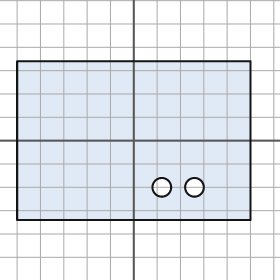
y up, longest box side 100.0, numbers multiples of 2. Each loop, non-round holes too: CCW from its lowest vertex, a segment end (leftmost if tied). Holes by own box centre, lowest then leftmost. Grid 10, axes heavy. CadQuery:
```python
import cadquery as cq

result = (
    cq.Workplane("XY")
    .moveTo(-50.0, -34.0)
    .lineTo(50.0, -34.0)
    .lineTo(50.0, 34.0)
    .lineTo(-50.0, 34.0)
    .close()
    .moveTo(12.0, -20.0)
    .circle(4.0)
    .moveTo(26.0, -20.0)
    .circle(4.0)
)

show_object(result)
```